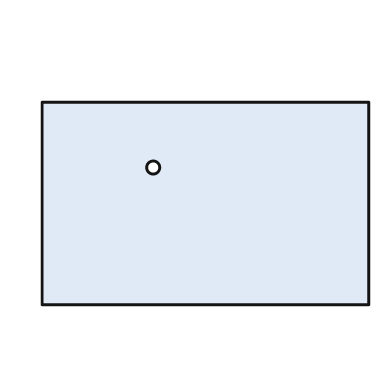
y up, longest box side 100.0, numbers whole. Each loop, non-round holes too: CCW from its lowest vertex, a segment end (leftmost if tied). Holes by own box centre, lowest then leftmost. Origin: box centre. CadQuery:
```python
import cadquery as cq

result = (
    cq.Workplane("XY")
    .moveTo(-50.0, -31.0)
    .lineTo(50.0, -31.0)
    .lineTo(50.0, 31.0)
    .lineTo(-50.0, 31.0)
    .close()
    .moveTo(-16.0, 11.0)
    .circle(2.0)
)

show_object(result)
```